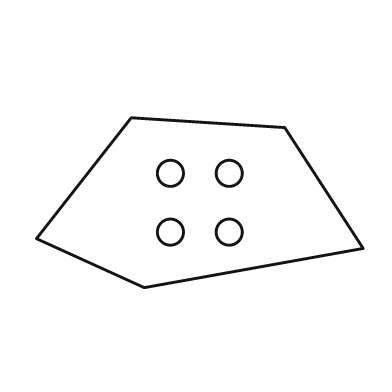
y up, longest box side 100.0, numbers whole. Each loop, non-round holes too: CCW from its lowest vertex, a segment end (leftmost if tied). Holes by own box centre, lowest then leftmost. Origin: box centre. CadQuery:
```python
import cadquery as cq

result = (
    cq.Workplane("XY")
    .moveTo(-17.0, -26.0)
    .lineTo(50.0, -14.0)
    .lineTo(26.0, 23.0)
    .lineTo(-21.0, 26.0)
    .lineTo(-50.0, -11.0)
    .close()
    .moveTo(-9.0, -9.0)
    .circle(4.0)
    .moveTo(9.0, -9.0)
    .circle(4.0)
    .moveTo(-9.0, 9.0)
    .circle(4.0)
    .moveTo(9.0, 9.0)
    .circle(4.0)
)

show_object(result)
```